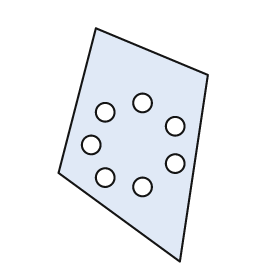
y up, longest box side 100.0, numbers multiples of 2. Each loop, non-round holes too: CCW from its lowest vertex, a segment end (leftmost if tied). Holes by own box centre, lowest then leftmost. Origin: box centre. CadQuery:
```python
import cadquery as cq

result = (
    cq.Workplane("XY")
    .moveTo(20.0, -50.0)
    .lineTo(32.0, 30.0)
    .lineTo(-16.0, 50.0)
    .lineTo(-32.0, -12.0)
    .close()
    .moveTo(4.0, -18.0)
    .circle(4.0)
    .moveTo(-12.0, -14.0)
    .circle(4.0)
    .moveTo(18.0, -8.0)
    .circle(4.0)
    .moveTo(-18.0, 0.0)
    .circle(4.0)
    .moveTo(18.0, 8.0)
    .circle(4.0)
    .moveTo(-12.0, 14.0)
    .circle(4.0)
    .moveTo(4.0, 18.0)
    .circle(4.0)
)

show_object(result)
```